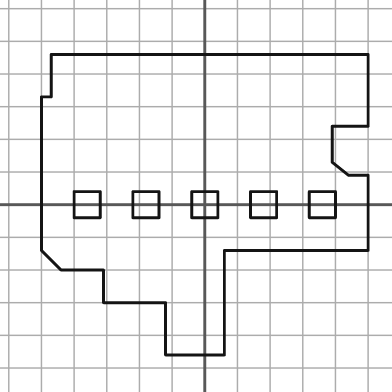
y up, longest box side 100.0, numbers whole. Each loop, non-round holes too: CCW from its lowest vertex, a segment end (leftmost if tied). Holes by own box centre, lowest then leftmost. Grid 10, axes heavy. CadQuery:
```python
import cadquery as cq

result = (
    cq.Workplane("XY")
    .moveTo(-12.0, -46.0)
    .lineTo(6.0, -46.0)
    .lineTo(6.0, -14.0)
    .lineTo(50.0, -14.0)
    .lineTo(50.0, 9.0)
    .lineTo(44.0, 9.0)
    .lineTo(39.0, 13.0)
    .lineTo(39.0, 24.0)
    .lineTo(50.0, 24.0)
    .lineTo(50.0, 46.0)
    .lineTo(-47.0, 46.0)
    .lineTo(-47.0, 33.0)
    .lineTo(-50.0, 33.0)
    .lineTo(-50.0, -14.0)
    .lineTo(-44.0, -20.0)
    .lineTo(-31.0, -20.0)
    .lineTo(-31.0, -30.0)
    .lineTo(-12.0, -30.0)
    .close()
    .moveTo(-40.0, -4.0)
    .lineTo(-32.0, -4.0)
    .lineTo(-32.0, 4.0)
    .lineTo(-40.0, 4.0)
    .close()
    .moveTo(-22.0, -4.0)
    .lineTo(-14.0, -4.0)
    .lineTo(-14.0, 4.0)
    .lineTo(-22.0, 4.0)
    .close()
    .moveTo(-4.0, -4.0)
    .lineTo(4.0, -4.0)
    .lineTo(4.0, 4.0)
    .lineTo(-4.0, 4.0)
    .close()
    .moveTo(14.0, -4.0)
    .lineTo(22.0, -4.0)
    .lineTo(22.0, 4.0)
    .lineTo(14.0, 4.0)
    .close()
    .moveTo(32.0, -4.0)
    .lineTo(40.0, -4.0)
    .lineTo(40.0, 4.0)
    .lineTo(32.0, 4.0)
    .close()
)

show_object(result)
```